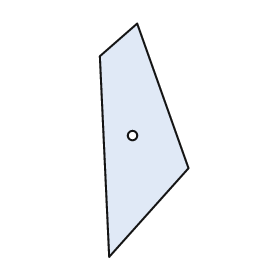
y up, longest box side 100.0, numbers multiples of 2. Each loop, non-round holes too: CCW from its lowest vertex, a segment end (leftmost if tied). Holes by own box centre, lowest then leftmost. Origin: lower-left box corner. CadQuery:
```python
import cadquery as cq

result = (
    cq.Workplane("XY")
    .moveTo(4.0, 0.0)
    .lineTo(38.0, 38.0)
    .lineTo(16.0, 100.0)
    .lineTo(0.0, 86.0)
    .close()
    .moveTo(14.0, 52.0)
    .circle(2.0)
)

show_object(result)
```